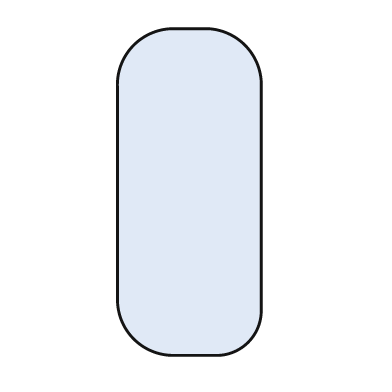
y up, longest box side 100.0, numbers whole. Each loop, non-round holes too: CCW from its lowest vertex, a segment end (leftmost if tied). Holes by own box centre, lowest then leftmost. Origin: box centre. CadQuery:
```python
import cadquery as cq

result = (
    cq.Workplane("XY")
    .moveTo(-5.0, -50.0)
    .lineTo(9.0, -50.0)
    .threePointArc((18.0, -46.0), (22.0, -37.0))
    .lineTo(22.0, 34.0)
    .threePointArc((17.0, 45.0), (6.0, 50.0))
    .lineTo(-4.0, 50.0)
    .threePointArc((-17.0, 45.0), (-22.0, 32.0))
    .lineTo(-22.0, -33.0)
    .threePointArc((-17.0, -45.0), (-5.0, -50.0))
    .close()
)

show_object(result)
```